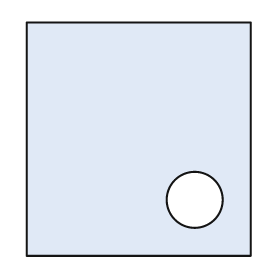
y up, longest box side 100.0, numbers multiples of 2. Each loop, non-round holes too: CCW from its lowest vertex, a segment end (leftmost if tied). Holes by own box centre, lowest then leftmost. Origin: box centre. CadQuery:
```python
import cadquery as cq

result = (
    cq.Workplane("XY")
    .moveTo(-48.0, -50.0)
    .lineTo(48.0, -50.0)
    .lineTo(48.0, 50.0)
    .lineTo(-48.0, 50.0)
    .close()
    .moveTo(24.0, -26.0)
    .circle(12.0)
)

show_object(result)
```